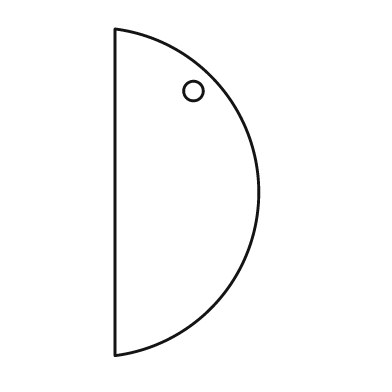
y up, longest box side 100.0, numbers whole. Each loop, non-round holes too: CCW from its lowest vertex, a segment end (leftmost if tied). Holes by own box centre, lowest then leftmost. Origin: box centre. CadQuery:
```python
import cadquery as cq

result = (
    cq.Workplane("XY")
    .moveTo(-22.0, -50.0)
    .threePointArc((22.0, 0.0), (-22.0, 50.0))
    .close()
    .moveTo(2.0, 31.0)
    .circle(3.0)
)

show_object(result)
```